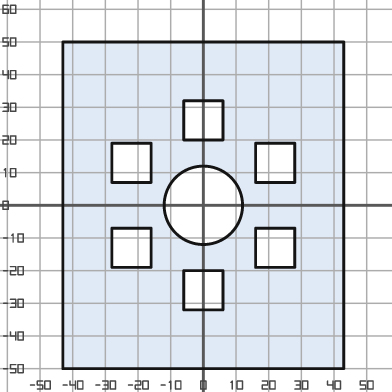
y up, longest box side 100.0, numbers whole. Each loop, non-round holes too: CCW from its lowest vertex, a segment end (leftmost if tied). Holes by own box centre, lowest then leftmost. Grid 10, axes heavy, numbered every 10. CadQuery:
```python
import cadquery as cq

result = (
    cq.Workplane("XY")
    .moveTo(-43.0, -50.0)
    .lineTo(43.0, -50.0)
    .lineTo(43.0, 50.0)
    .lineTo(-43.0, 50.0)
    .close()
    .moveTo(-6.0, -32.0)
    .lineTo(6.0, -32.0)
    .lineTo(6.0, -20.0)
    .lineTo(-6.0, -20.0)
    .close()
    .moveTo(-28.0, -19.0)
    .lineTo(-16.0, -19.0)
    .lineTo(-16.0, -7.0)
    .lineTo(-28.0, -7.0)
    .close()
    .moveTo(16.0, -19.0)
    .lineTo(28.0, -19.0)
    .lineTo(28.0, -7.0)
    .lineTo(16.0, -7.0)
    .close()
    .moveTo(0.0, 0.0)
    .circle(12.0)
    .moveTo(-28.0, 7.0)
    .lineTo(-16.0, 7.0)
    .lineTo(-16.0, 19.0)
    .lineTo(-28.0, 19.0)
    .close()
    .moveTo(16.0, 7.0)
    .lineTo(28.0, 7.0)
    .lineTo(28.0, 19.0)
    .lineTo(16.0, 19.0)
    .close()
    .moveTo(-6.0, 20.0)
    .lineTo(6.0, 20.0)
    .lineTo(6.0, 32.0)
    .lineTo(-6.0, 32.0)
    .close()
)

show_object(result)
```